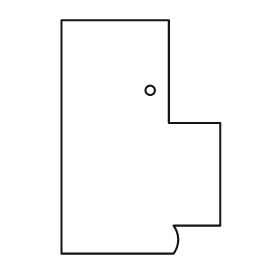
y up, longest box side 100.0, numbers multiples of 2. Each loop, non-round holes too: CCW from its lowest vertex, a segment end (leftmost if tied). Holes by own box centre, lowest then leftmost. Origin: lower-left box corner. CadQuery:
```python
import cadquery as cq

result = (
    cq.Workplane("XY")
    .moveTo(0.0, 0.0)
    .lineTo(48.0, 0.0)
    .threePointArc((50.0, 6.0), (48.0, 12.0))
    .lineTo(68.0, 12.0)
    .lineTo(68.0, 56.0)
    .lineTo(46.0, 56.0)
    .lineTo(46.0, 100.0)
    .lineTo(0.0, 100.0)
    .close()
    .moveTo(38.0, 70.0)
    .circle(2.0)
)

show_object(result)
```